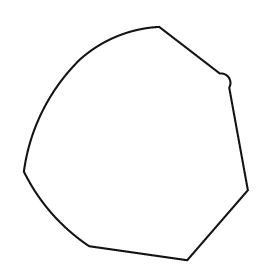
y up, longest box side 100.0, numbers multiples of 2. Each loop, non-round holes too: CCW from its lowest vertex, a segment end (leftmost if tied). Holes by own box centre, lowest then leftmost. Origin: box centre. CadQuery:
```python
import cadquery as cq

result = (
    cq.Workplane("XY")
    .moveTo(22.0, -50.0)
    .lineTo(48.0, -20.0)
    .lineTo(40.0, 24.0)
    .threePointArc((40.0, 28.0), (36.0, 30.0))
    .lineTo(10.0, 50.0)
    .threePointArc((-8.0, 46.0), (-24.0, 36.0))
    .threePointArc((-40.0, 14.0), (-48.0, -12.0))
    .threePointArc((-36.0, -30.0), (-20.0, -44.0))
    .close()
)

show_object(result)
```